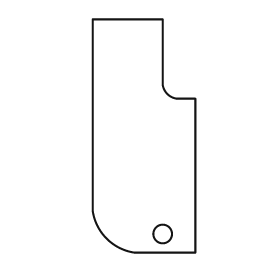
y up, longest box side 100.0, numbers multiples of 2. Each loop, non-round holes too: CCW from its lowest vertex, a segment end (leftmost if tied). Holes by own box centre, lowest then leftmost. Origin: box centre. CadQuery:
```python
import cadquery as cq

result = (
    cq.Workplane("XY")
    .moveTo(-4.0, -50.0)
    .lineTo(22.0, -50.0)
    .lineTo(22.0, 16.0)
    .lineTo(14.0, 16.0)
    .threePointArc((10.0, 18.0), (8.0, 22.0))
    .lineTo(8.0, 50.0)
    .lineTo(-22.0, 50.0)
    .lineTo(-22.0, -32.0)
    .threePointArc((-16.0, -44.0), (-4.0, -50.0))
    .close()
    .moveTo(8.0, -42.0)
    .circle(4.0)
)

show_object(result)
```